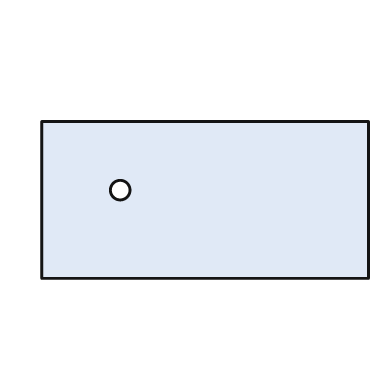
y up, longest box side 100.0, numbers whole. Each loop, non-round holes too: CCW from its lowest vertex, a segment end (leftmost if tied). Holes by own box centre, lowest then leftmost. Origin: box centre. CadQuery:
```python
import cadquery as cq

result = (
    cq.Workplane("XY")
    .moveTo(-50.0, -24.0)
    .lineTo(50.0, -24.0)
    .lineTo(50.0, 24.0)
    .lineTo(-50.0, 24.0)
    .close()
    .moveTo(-26.0, 3.0)
    .circle(3.0)
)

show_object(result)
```